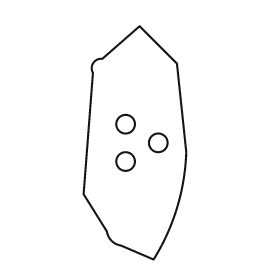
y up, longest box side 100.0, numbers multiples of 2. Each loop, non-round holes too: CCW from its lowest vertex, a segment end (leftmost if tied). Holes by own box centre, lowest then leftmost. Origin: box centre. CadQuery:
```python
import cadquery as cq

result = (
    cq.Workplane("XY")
    .moveTo(8.0, -50.0)
    .threePointArc((18.0, -28.0), (22.0, -4.0))
    .lineTo(18.0, 34.0)
    .lineTo(2.0, 50.0)
    .lineTo(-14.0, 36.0)
    .threePointArc((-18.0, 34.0), (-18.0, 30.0))
    .lineTo(-22.0, -22.0)
    .lineTo(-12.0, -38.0)
    .threePointArc((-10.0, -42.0), (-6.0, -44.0))
    .close()
    .moveTo(-4.0, -8.0)
    .circle(4.0)
    .moveTo(10.0, 0.0)
    .circle(4.0)
    .moveTo(-4.0, 8.0)
    .circle(4.0)
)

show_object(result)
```